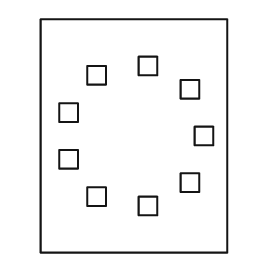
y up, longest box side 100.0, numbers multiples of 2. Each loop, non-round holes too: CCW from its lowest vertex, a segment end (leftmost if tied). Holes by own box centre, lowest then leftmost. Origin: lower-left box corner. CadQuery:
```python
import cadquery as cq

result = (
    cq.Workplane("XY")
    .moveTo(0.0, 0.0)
    .lineTo(80.0, 0.0)
    .lineTo(80.0, 100.0)
    .lineTo(0.0, 100.0)
    .close()
    .moveTo(42.0, 16.0)
    .lineTo(50.0, 16.0)
    .lineTo(50.0, 24.0)
    .lineTo(42.0, 24.0)
    .close()
    .moveTo(20.0, 20.0)
    .lineTo(28.0, 20.0)
    .lineTo(28.0, 28.0)
    .lineTo(20.0, 28.0)
    .close()
    .moveTo(60.0, 26.0)
    .lineTo(68.0, 26.0)
    .lineTo(68.0, 34.0)
    .lineTo(60.0, 34.0)
    .close()
    .moveTo(8.0, 36.0)
    .lineTo(16.0, 36.0)
    .lineTo(16.0, 44.0)
    .lineTo(8.0, 44.0)
    .close()
    .moveTo(66.0, 46.0)
    .lineTo(74.0, 46.0)
    .lineTo(74.0, 54.0)
    .lineTo(66.0, 54.0)
    .close()
    .moveTo(8.0, 56.0)
    .lineTo(16.0, 56.0)
    .lineTo(16.0, 64.0)
    .lineTo(8.0, 64.0)
    .close()
    .moveTo(60.0, 66.0)
    .lineTo(68.0, 66.0)
    .lineTo(68.0, 74.0)
    .lineTo(60.0, 74.0)
    .close()
    .moveTo(20.0, 72.0)
    .lineTo(28.0, 72.0)
    .lineTo(28.0, 80.0)
    .lineTo(20.0, 80.0)
    .close()
    .moveTo(42.0, 76.0)
    .lineTo(50.0, 76.0)
    .lineTo(50.0, 84.0)
    .lineTo(42.0, 84.0)
    .close()
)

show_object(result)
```